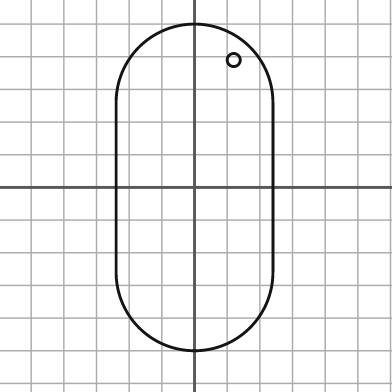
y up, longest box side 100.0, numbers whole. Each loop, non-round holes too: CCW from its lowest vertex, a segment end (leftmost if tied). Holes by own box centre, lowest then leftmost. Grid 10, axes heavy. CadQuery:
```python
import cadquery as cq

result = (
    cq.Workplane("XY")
    .moveTo(-24.0, -26.0)
    .threePointArc((0.0, -50.0), (24.0, -26.0))
    .lineTo(24.0, 26.0)
    .threePointArc((0.0, 50.0), (-24.0, 26.0))
    .close()
    .moveTo(12.0, 39.0)
    .circle(2.0)
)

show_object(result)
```